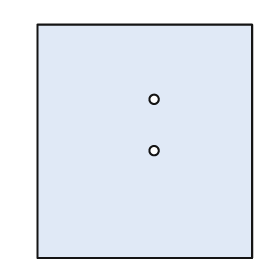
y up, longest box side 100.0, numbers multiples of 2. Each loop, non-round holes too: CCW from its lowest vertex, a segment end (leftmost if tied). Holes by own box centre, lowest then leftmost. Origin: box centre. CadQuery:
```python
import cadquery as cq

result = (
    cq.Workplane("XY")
    .moveTo(-46.0, -50.0)
    .lineTo(46.0, -50.0)
    .lineTo(46.0, 50.0)
    .lineTo(-46.0, 50.0)
    .close()
    .moveTo(4.0, -4.0)
    .circle(2.0)
    .moveTo(4.0, 18.0)
    .circle(2.0)
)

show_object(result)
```